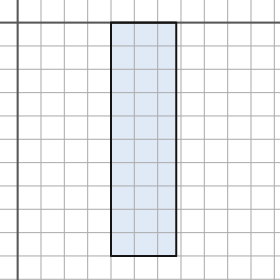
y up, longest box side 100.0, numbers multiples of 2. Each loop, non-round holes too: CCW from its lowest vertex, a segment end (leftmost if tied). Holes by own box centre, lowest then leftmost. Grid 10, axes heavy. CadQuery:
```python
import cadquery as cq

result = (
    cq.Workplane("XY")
    .moveTo(40.0, -100.0)
    .lineTo(68.0, -100.0)
    .lineTo(68.0, 0.0)
    .lineTo(40.0, 0.0)
    .close()
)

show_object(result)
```